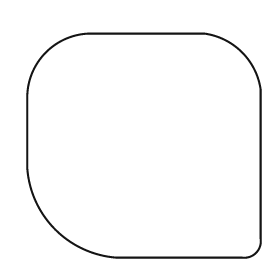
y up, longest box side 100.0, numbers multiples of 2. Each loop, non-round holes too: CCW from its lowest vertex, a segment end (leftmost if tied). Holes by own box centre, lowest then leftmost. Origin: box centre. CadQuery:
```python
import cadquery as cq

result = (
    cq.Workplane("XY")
    .moveTo(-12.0, -48.0)
    .lineTo(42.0, -48.0)
    .threePointArc((48.0, -46.0), (50.0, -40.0))
    .lineTo(50.0, 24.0)
    .threePointArc((42.0, 40.0), (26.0, 48.0))
    .lineTo(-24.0, 48.0)
    .threePointArc((-42.0, 40.0), (-50.0, 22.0))
    .lineTo(-50.0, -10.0)
    .threePointArc((-38.0, -36.0), (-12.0, -48.0))
    .close()
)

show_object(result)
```